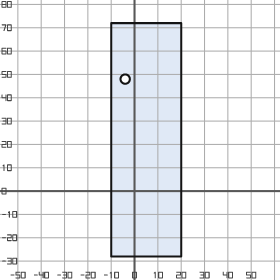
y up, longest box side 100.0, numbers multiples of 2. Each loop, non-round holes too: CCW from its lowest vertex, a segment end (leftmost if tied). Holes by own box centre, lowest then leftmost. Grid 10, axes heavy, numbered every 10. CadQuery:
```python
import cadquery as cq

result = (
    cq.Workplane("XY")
    .moveTo(-10.0, -28.0)
    .lineTo(20.0, -28.0)
    .lineTo(20.0, 72.0)
    .lineTo(-10.0, 72.0)
    .close()
    .moveTo(-4.0, 48.0)
    .circle(2.0)
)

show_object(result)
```